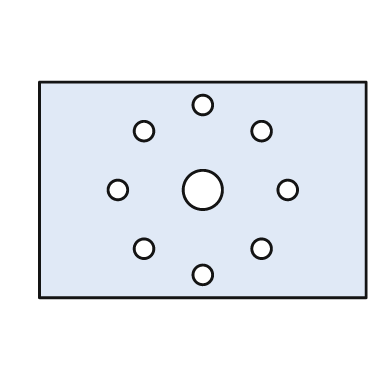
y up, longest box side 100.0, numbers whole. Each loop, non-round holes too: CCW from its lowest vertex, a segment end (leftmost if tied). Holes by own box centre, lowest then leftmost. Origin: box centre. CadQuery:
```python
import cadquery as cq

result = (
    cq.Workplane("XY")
    .moveTo(-50.0, -33.0)
    .lineTo(50.0, -33.0)
    .lineTo(50.0, 33.0)
    .lineTo(-50.0, 33.0)
    .close()
    .moveTo(0.0, -26.0)
    .circle(3.0)
    .moveTo(-18.0, -18.0)
    .circle(3.0)
    .moveTo(18.0, -18.0)
    .circle(3.0)
    .moveTo(-26.0, 0.0)
    .circle(3.0)
    .moveTo(0.0, 0.0)
    .circle(6.0)
    .moveTo(26.0, 0.0)
    .circle(3.0)
    .moveTo(-18.0, 18.0)
    .circle(3.0)
    .moveTo(18.0, 18.0)
    .circle(3.0)
    .moveTo(0.0, 26.0)
    .circle(3.0)
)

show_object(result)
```